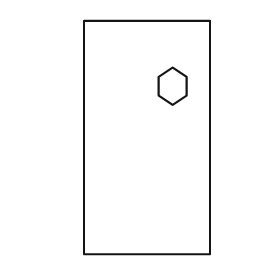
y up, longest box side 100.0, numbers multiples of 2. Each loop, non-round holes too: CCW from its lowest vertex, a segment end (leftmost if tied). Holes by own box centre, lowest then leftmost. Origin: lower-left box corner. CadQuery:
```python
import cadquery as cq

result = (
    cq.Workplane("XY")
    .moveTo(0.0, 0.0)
    .lineTo(54.0, 0.0)
    .lineTo(54.0, 100.0)
    .lineTo(0.0, 100.0)
    .close()
    .moveTo(38.0, 64.0)
    .lineTo(44.0, 68.0)
    .lineTo(44.0, 76.0)
    .lineTo(38.0, 80.0)
    .lineTo(32.0, 76.0)
    .lineTo(32.0, 68.0)
    .close()
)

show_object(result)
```